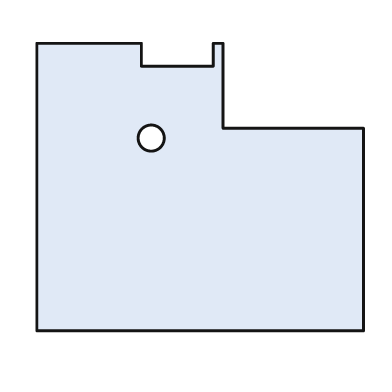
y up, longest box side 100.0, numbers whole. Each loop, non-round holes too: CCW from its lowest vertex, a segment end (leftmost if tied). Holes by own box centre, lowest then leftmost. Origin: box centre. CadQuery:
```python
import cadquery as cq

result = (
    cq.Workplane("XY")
    .moveTo(-50.0, -44.0)
    .lineTo(50.0, -44.0)
    .lineTo(50.0, 18.0)
    .lineTo(7.0, 18.0)
    .lineTo(7.0, 44.0)
    .lineTo(4.0, 44.0)
    .lineTo(4.0, 37.0)
    .lineTo(-18.0, 37.0)
    .lineTo(-18.0, 44.0)
    .lineTo(-50.0, 44.0)
    .close()
    .moveTo(-15.0, 15.0)
    .circle(4.0)
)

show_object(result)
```